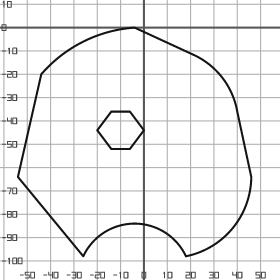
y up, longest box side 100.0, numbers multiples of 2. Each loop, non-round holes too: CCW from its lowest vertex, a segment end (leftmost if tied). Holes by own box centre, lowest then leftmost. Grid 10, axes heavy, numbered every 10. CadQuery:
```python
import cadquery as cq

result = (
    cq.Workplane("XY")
    .moveTo(-26.0, -98.0)
    .threePointArc((-4.0, -84.0), (18.0, -98.0))
    .threePointArc((38.0, -86.0), (46.0, -64.0))
    .lineTo(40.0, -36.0)
    .threePointArc((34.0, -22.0), (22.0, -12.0))
    .lineTo(-4.0, 0.0)
    .threePointArc((-26.0, -6.0), (-44.0, -20.0))
    .lineTo(-54.0, -64.0)
    .close()
    .moveTo(-14.0, -52.0)
    .lineTo(-6.0, -52.0)
    .lineTo(0.0, -44.0)
    .lineTo(-6.0, -36.0)
    .lineTo(-14.0, -36.0)
    .lineTo(-20.0, -44.0)
    .close()
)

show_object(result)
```